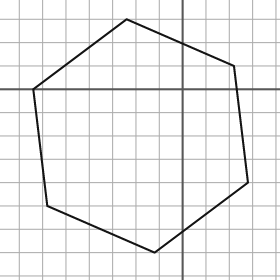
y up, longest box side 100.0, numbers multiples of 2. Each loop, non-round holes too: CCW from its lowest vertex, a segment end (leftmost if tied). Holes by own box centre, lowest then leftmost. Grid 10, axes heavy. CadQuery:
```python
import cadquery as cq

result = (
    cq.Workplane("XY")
    .moveTo(-12.0, -70.0)
    .lineTo(28.0, -40.0)
    .lineTo(22.0, 10.0)
    .lineTo(-24.0, 30.0)
    .lineTo(-64.0, 0.0)
    .lineTo(-58.0, -50.0)
    .close()
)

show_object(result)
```